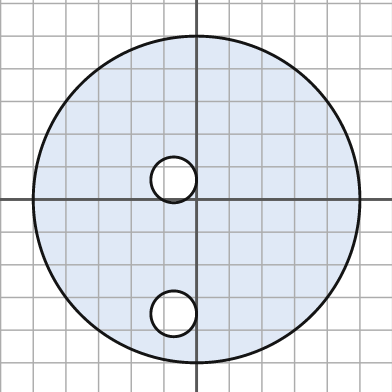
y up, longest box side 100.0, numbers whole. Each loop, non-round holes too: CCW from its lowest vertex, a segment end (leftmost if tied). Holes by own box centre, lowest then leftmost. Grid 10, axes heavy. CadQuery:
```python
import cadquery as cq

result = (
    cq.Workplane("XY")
    .moveTo(0.0, 0.0)
    .circle(50.0)
    .moveTo(-7.0, -35.0)
    .circle(7.0)
    .moveTo(-7.0, 6.0)
    .circle(7.0)
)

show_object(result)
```